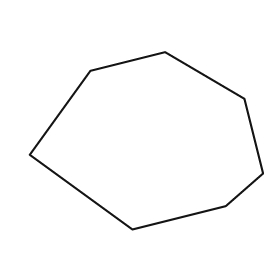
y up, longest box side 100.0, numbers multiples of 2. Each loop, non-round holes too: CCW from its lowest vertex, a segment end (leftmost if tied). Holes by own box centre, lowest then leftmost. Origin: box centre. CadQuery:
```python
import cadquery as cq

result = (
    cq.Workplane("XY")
    .moveTo(-6.0, -38.0)
    .lineTo(34.0, -28.0)
    .lineTo(50.0, -14.0)
    .lineTo(42.0, 18.0)
    .lineTo(8.0, 38.0)
    .lineTo(-24.0, 30.0)
    .lineTo(-50.0, -6.0)
    .close()
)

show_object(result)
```